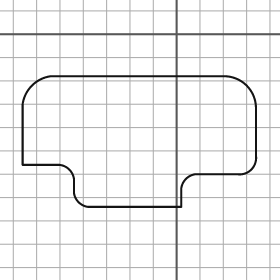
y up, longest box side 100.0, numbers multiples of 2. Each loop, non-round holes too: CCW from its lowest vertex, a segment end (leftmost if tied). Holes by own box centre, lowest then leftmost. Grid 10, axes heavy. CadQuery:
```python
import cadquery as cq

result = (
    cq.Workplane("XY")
    .moveTo(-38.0, -74.0)
    .lineTo(2.0, -74.0)
    .lineTo(2.0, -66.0)
    .threePointArc((4.0, -62.0), (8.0, -60.0))
    .lineTo(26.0, -60.0)
    .threePointArc((32.0, -58.0), (34.0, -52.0))
    .lineTo(34.0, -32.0)
    .threePointArc((30.0, -22.0), (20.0, -18.0))
    .lineTo(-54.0, -18.0)
    .threePointArc((-62.0, -22.0), (-66.0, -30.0))
    .lineTo(-66.0, -56.0)
    .lineTo(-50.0, -56.0)
    .threePointArc((-46.0, -58.0), (-44.0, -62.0))
    .lineTo(-44.0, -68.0)
    .threePointArc((-42.0, -72.0), (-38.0, -74.0))
    .close()
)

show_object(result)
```